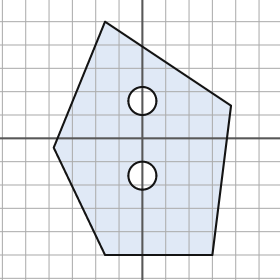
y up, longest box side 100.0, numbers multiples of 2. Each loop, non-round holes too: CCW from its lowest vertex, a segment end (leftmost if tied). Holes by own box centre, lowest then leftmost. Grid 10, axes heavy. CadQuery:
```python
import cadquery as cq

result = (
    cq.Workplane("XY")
    .moveTo(-16.0, -50.0)
    .lineTo(30.0, -50.0)
    .lineTo(38.0, 14.0)
    .lineTo(-16.0, 50.0)
    .lineTo(-38.0, -4.0)
    .close()
    .moveTo(0.0, -16.0)
    .circle(6.0)
    .moveTo(0.0, 16.0)
    .circle(6.0)
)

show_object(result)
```